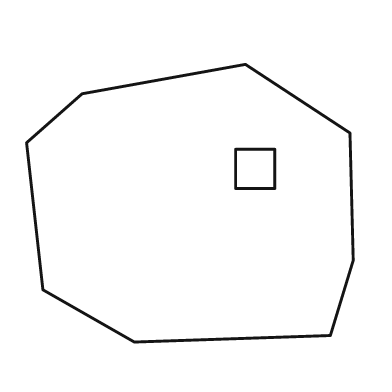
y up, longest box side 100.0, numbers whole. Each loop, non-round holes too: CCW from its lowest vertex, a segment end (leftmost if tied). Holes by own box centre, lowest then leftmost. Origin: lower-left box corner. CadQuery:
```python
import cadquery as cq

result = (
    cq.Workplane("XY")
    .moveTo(33.0, 0.0)
    .lineTo(93.0, 2.0)
    .lineTo(100.0, 25.0)
    .lineTo(99.0, 64.0)
    .lineTo(67.0, 85.0)
    .lineTo(17.0, 76.0)
    .lineTo(0.0, 61.0)
    .lineTo(5.0, 16.0)
    .close()
    .moveTo(64.0, 47.0)
    .lineTo(76.0, 47.0)
    .lineTo(76.0, 59.0)
    .lineTo(64.0, 59.0)
    .close()
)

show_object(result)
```